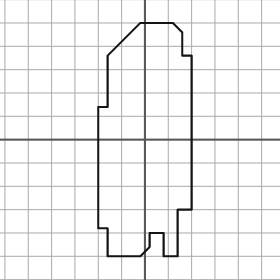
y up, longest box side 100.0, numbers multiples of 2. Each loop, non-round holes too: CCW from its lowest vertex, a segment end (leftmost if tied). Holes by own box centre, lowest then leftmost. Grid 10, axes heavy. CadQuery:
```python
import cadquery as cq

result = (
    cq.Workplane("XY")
    .moveTo(-16.0, -50.0)
    .lineTo(-2.0, -50.0)
    .lineTo(2.0, -46.0)
    .lineTo(2.0, -40.0)
    .lineTo(8.0, -40.0)
    .lineTo(8.0, -50.0)
    .lineTo(14.0, -50.0)
    .lineTo(14.0, -30.0)
    .lineTo(20.0, -30.0)
    .lineTo(20.0, 36.0)
    .lineTo(16.0, 36.0)
    .lineTo(16.0, 46.0)
    .lineTo(12.0, 50.0)
    .lineTo(-2.0, 50.0)
    .lineTo(-16.0, 36.0)
    .lineTo(-16.0, 14.0)
    .lineTo(-20.0, 14.0)
    .lineTo(-20.0, -38.0)
    .lineTo(-16.0, -38.0)
    .close()
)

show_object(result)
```